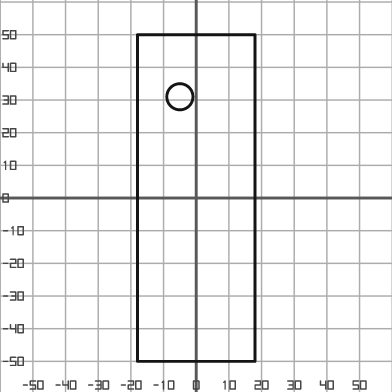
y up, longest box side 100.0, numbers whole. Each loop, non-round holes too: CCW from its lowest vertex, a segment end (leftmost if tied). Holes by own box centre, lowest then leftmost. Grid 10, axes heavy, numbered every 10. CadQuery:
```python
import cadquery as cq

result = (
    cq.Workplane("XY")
    .moveTo(-18.0, -50.0)
    .lineTo(18.0, -50.0)
    .lineTo(18.0, 50.0)
    .lineTo(-18.0, 50.0)
    .close()
    .moveTo(-5.0, 31.0)
    .circle(4.0)
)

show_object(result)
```